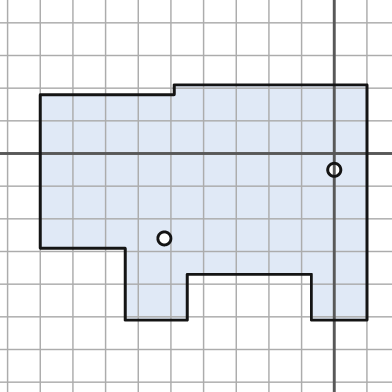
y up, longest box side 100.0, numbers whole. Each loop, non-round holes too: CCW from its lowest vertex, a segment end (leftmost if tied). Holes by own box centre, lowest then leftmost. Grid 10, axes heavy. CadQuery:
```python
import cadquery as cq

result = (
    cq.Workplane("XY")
    .moveTo(-64.0, -51.0)
    .lineTo(-45.0, -51.0)
    .lineTo(-45.0, -37.0)
    .lineTo(-7.0, -37.0)
    .lineTo(-7.0, -51.0)
    .lineTo(10.0, -51.0)
    .lineTo(10.0, 21.0)
    .lineTo(-49.0, 21.0)
    .lineTo(-49.0, 18.0)
    .lineTo(-90.0, 18.0)
    .lineTo(-90.0, -29.0)
    .lineTo(-64.0, -29.0)
    .close()
    .moveTo(-52.0, -26.0)
    .circle(2.0)
    .moveTo(0.0, -5.0)
    .circle(2.0)
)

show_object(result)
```